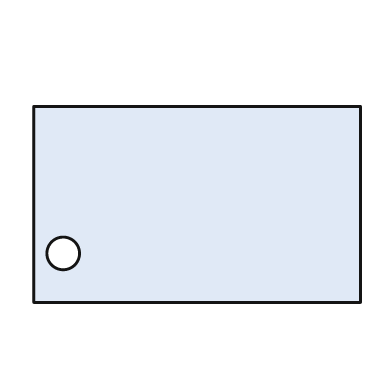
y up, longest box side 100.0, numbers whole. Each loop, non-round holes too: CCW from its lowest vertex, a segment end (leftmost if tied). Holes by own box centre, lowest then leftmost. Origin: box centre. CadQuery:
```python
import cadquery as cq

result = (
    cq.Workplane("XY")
    .moveTo(-50.0, -30.0)
    .lineTo(50.0, -30.0)
    .lineTo(50.0, 30.0)
    .lineTo(-50.0, 30.0)
    .close()
    .moveTo(-41.0, -15.0)
    .circle(5.0)
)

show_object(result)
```